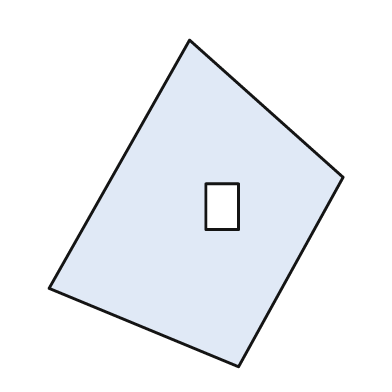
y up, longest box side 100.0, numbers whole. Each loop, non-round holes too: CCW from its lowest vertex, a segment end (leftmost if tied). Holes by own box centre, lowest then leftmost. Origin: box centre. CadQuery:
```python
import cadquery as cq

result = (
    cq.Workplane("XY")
    .moveTo(13.0, -50.0)
    .lineTo(45.0, 8.0)
    .lineTo(-2.0, 50.0)
    .lineTo(-45.0, -26.0)
    .close()
    .moveTo(3.0, -8.0)
    .lineTo(13.0, -8.0)
    .lineTo(13.0, 6.0)
    .lineTo(3.0, 6.0)
    .close()
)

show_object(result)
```